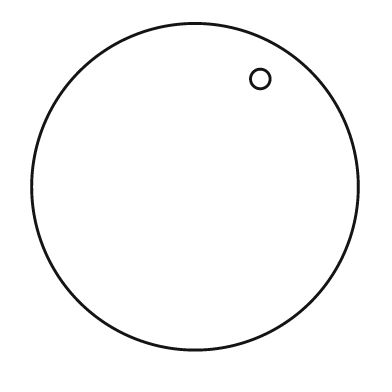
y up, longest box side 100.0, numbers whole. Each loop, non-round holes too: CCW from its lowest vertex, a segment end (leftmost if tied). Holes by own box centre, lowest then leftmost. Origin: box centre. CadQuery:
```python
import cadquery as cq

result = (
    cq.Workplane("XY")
    .moveTo(0.0, 0.0)
    .circle(50.0)
    .moveTo(20.0, 33.0)
    .circle(3.0)
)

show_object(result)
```